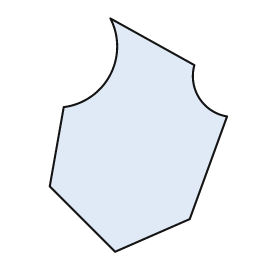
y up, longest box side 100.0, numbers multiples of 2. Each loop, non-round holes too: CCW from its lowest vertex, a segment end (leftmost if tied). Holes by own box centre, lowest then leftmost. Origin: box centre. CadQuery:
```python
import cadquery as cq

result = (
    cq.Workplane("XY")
    .moveTo(-10.0, -50.0)
    .lineTo(22.0, -36.0)
    .lineTo(38.0, 8.0)
    .threePointArc((26.0, 16.0), (24.0, 30.0))
    .lineTo(-12.0, 50.0)
    .threePointArc((-12.0, 26.0), (-32.0, 12.0))
    .lineTo(-38.0, -22.0)
    .close()
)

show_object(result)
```